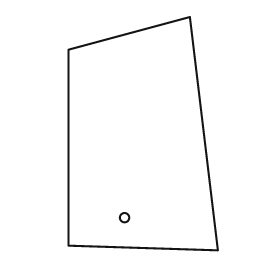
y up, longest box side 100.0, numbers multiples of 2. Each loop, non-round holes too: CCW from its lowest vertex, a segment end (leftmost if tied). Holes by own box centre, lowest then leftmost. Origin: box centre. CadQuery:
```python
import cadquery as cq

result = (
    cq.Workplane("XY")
    .moveTo(32.0, -50.0)
    .lineTo(20.0, 50.0)
    .lineTo(-32.0, 36.0)
    .lineTo(-32.0, -48.0)
    .close()
    .moveTo(-8.0, -36.0)
    .circle(2.0)
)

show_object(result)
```